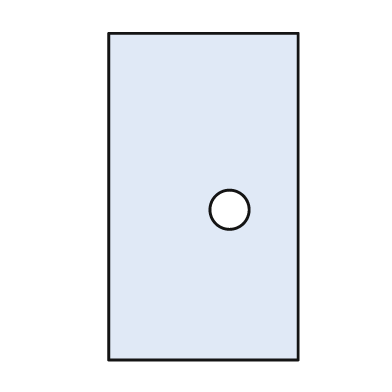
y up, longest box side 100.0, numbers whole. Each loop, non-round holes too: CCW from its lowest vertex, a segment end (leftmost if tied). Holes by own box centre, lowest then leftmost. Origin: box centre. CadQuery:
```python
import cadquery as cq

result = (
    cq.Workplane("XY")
    .moveTo(-29.0, -50.0)
    .lineTo(29.0, -50.0)
    .lineTo(29.0, 50.0)
    .lineTo(-29.0, 50.0)
    .close()
    .moveTo(8.0, -4.0)
    .circle(6.0)
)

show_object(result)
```